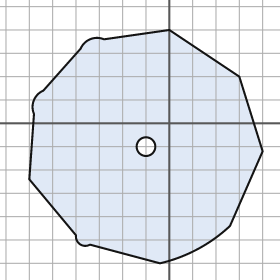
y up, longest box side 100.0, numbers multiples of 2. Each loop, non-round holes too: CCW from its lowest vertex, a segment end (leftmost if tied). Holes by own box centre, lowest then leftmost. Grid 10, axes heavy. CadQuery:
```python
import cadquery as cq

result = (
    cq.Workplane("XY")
    .moveTo(-4.0, -60.0)
    .threePointArc((12.0, -54.0), (26.0, -44.0))
    .lineTo(40.0, -12.0)
    .lineTo(30.0, 20.0)
    .lineTo(0.0, 40.0)
    .lineTo(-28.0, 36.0)
    .threePointArc((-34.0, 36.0), (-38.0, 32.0))
    .lineTo(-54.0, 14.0)
    .threePointArc((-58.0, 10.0), (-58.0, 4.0))
    .lineTo(-60.0, -24.0)
    .lineTo(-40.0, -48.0)
    .threePointArc((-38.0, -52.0), (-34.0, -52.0))
    .close()
    .moveTo(-10.0, -10.0)
    .circle(4.0)
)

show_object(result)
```